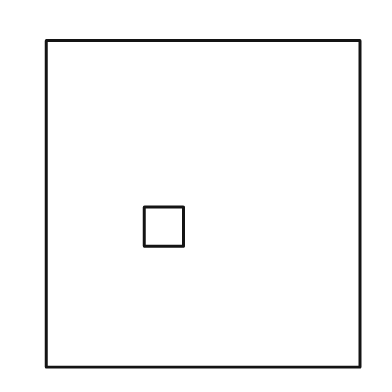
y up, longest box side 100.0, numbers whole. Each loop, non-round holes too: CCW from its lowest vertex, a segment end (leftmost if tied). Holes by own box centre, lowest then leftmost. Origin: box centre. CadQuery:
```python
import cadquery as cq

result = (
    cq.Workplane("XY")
    .moveTo(-48.0, -50.0)
    .lineTo(48.0, -50.0)
    .lineTo(48.0, 50.0)
    .lineTo(-48.0, 50.0)
    .close()
    .moveTo(-18.0, -13.0)
    .lineTo(-6.0, -13.0)
    .lineTo(-6.0, -1.0)
    .lineTo(-18.0, -1.0)
    .close()
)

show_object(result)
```